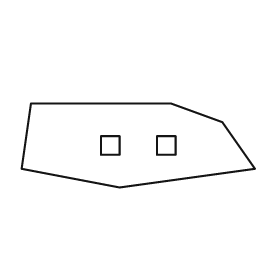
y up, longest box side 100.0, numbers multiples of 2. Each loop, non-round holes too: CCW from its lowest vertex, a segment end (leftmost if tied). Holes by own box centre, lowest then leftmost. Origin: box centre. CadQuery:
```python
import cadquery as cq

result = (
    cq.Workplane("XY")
    .moveTo(-8.0, -18.0)
    .lineTo(50.0, -10.0)
    .lineTo(36.0, 10.0)
    .lineTo(14.0, 18.0)
    .lineTo(-46.0, 18.0)
    .lineTo(-50.0, -10.0)
    .close()
    .moveTo(-16.0, -4.0)
    .lineTo(-8.0, -4.0)
    .lineTo(-8.0, 4.0)
    .lineTo(-16.0, 4.0)
    .close()
    .moveTo(8.0, -4.0)
    .lineTo(16.0, -4.0)
    .lineTo(16.0, 4.0)
    .lineTo(8.0, 4.0)
    .close()
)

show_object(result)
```